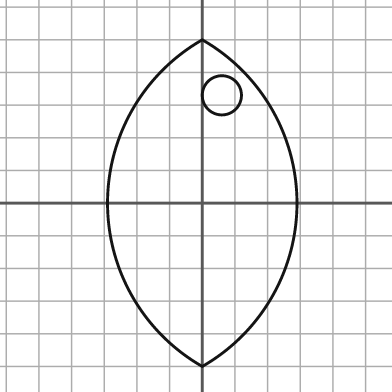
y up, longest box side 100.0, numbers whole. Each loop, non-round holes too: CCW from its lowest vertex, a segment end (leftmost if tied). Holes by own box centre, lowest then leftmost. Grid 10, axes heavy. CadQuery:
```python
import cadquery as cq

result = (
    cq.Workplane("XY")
    .moveTo(0.0, -50.0)
    .threePointArc((29.0, 0.0), (0.0, 50.0))
    .threePointArc((-29.0, 0.0), (0.0, -50.0))
    .close()
    .moveTo(6.0, 33.0)
    .circle(6.0)
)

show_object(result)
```